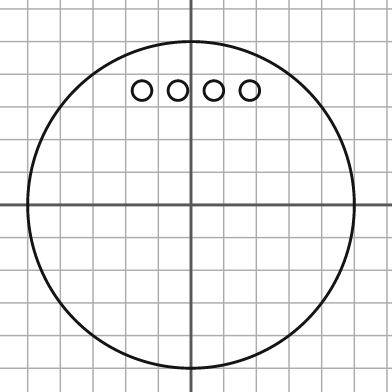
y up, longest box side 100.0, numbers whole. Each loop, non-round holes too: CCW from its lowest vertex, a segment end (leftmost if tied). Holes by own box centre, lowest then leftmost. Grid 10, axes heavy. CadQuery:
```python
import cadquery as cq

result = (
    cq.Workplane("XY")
    .moveTo(0.0, 0.0)
    .circle(50.0)
    .moveTo(-15.0, 35.0)
    .circle(3.0)
    .moveTo(-4.0, 35.0)
    .circle(3.0)
    .moveTo(7.0, 35.0)
    .circle(3.0)
    .moveTo(18.0, 35.0)
    .circle(3.0)
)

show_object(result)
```